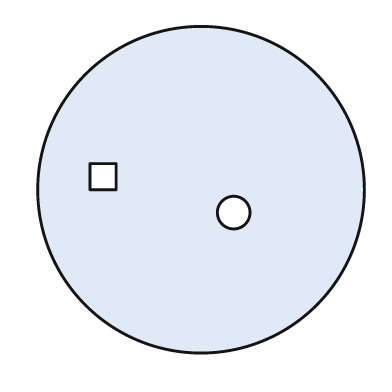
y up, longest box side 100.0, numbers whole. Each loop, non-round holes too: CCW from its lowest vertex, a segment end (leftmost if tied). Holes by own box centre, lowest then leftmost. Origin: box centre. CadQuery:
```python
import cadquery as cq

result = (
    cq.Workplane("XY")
    .moveTo(0.0, 0.0)
    .circle(50.0)
    .moveTo(10.0, -7.0)
    .circle(5.0)
    .moveTo(-34.0, 0.0)
    .lineTo(-26.0, 0.0)
    .lineTo(-26.0, 8.0)
    .lineTo(-34.0, 8.0)
    .close()
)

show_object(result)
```